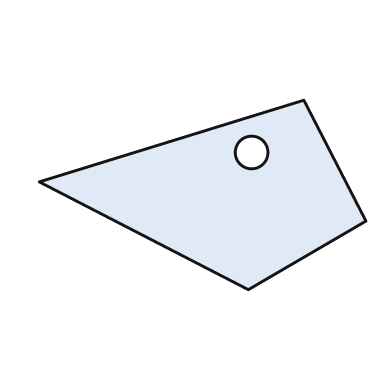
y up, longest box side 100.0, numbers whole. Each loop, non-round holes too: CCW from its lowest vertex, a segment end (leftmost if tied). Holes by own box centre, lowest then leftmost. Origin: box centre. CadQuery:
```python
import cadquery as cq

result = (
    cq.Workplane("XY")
    .moveTo(14.0, -29.0)
    .lineTo(50.0, -8.0)
    .lineTo(31.0, 29.0)
    .lineTo(-50.0, 4.0)
    .close()
    .moveTo(15.0, 13.0)
    .circle(5.0)
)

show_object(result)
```